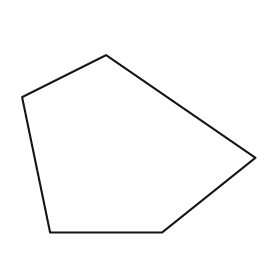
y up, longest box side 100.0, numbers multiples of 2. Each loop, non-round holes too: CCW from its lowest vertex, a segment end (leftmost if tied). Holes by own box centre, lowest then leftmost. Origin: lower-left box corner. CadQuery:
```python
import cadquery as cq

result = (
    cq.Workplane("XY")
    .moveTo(12.0, 0.0)
    .lineTo(60.0, 0.0)
    .lineTo(100.0, 32.0)
    .lineTo(36.0, 76.0)
    .lineTo(0.0, 58.0)
    .close()
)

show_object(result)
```